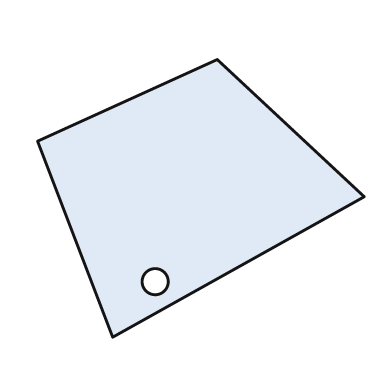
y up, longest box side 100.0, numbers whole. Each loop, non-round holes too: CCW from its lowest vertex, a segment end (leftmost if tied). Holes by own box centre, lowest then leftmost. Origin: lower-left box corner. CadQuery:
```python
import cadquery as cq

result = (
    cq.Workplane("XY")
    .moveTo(23.0, 0.0)
    .lineTo(100.0, 43.0)
    .lineTo(55.0, 85.0)
    .lineTo(0.0, 60.0)
    .close()
    .moveTo(36.0, 17.0)
    .circle(4.0)
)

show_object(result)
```